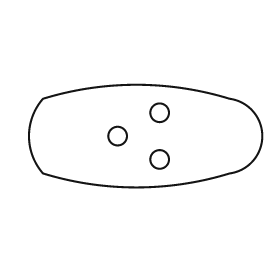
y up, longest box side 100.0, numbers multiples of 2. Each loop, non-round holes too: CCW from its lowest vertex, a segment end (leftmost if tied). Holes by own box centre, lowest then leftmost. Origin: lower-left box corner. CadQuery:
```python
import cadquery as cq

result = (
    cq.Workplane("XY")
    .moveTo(6.0, 6.0)
    .threePointArc((46.0, 0.0), (86.0, 6.0))
    .threePointArc((100.0, 22.0), (86.0, 38.0))
    .threePointArc((46.0, 44.0), (6.0, 38.0))
    .threePointArc((0.0, 22.0), (6.0, 6.0))
    .close()
    .moveTo(56.0, 12.0)
    .circle(4.0)
    .moveTo(38.0, 22.0)
    .circle(4.0)
    .moveTo(56.0, 32.0)
    .circle(4.0)
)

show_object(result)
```